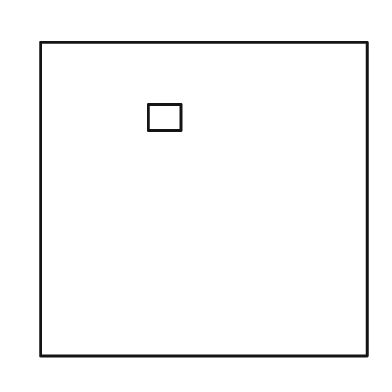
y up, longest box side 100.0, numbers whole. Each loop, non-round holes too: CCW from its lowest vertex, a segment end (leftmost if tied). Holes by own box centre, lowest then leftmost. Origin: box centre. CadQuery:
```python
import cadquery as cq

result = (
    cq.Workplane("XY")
    .moveTo(-50.0, -48.0)
    .lineTo(50.0, -48.0)
    .lineTo(50.0, 48.0)
    .lineTo(-50.0, 48.0)
    .close()
    .moveTo(-17.0, 21.0)
    .lineTo(-7.0, 21.0)
    .lineTo(-7.0, 29.0)
    .lineTo(-17.0, 29.0)
    .close()
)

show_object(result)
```